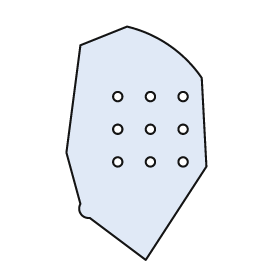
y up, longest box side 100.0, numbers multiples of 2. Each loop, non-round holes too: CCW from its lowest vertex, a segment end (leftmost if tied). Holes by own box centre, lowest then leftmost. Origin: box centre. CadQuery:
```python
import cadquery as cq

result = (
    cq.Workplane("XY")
    .moveTo(4.0, -50.0)
    .lineTo(30.0, -10.0)
    .lineTo(28.0, 28.0)
    .threePointArc((14.0, 42.0), (-4.0, 50.0))
    .lineTo(-24.0, 42.0)
    .lineTo(-30.0, -4.0)
    .lineTo(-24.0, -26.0)
    .threePointArc((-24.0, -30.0), (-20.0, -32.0))
    .close()
    .moveTo(-8.0, -8.0)
    .circle(2.0)
    .moveTo(6.0, -8.0)
    .circle(2.0)
    .moveTo(20.0, -8.0)
    .circle(2.0)
    .moveTo(-8.0, 6.0)
    .circle(2.0)
    .moveTo(6.0, 6.0)
    .circle(2.0)
    .moveTo(20.0, 6.0)
    .circle(2.0)
    .moveTo(-8.0, 20.0)
    .circle(2.0)
    .moveTo(6.0, 20.0)
    .circle(2.0)
    .moveTo(20.0, 20.0)
    .circle(2.0)
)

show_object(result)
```